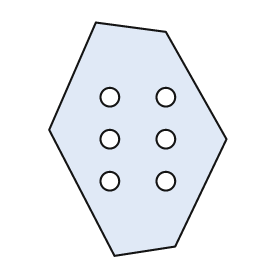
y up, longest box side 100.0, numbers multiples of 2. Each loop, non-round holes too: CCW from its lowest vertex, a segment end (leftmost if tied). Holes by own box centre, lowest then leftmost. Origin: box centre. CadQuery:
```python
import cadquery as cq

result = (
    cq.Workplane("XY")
    .moveTo(-10.0, -50.0)
    .lineTo(16.0, -46.0)
    .lineTo(38.0, 0.0)
    .lineTo(12.0, 46.0)
    .lineTo(-18.0, 50.0)
    .lineTo(-38.0, 4.0)
    .close()
    .moveTo(-12.0, -18.0)
    .circle(4.0)
    .moveTo(12.0, -18.0)
    .circle(4.0)
    .moveTo(-12.0, 0.0)
    .circle(4.0)
    .moveTo(12.0, 0.0)
    .circle(4.0)
    .moveTo(-12.0, 18.0)
    .circle(4.0)
    .moveTo(12.0, 18.0)
    .circle(4.0)
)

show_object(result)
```